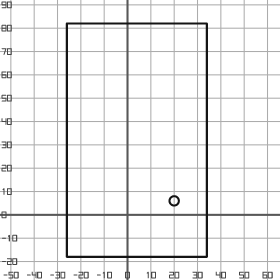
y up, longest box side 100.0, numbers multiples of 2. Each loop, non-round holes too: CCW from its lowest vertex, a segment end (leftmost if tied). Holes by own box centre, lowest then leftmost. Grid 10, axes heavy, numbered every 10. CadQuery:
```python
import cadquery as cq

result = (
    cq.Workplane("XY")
    .moveTo(-26.0, -18.0)
    .lineTo(34.0, -18.0)
    .lineTo(34.0, 82.0)
    .lineTo(-26.0, 82.0)
    .close()
    .moveTo(20.0, 6.0)
    .circle(2.0)
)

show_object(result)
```